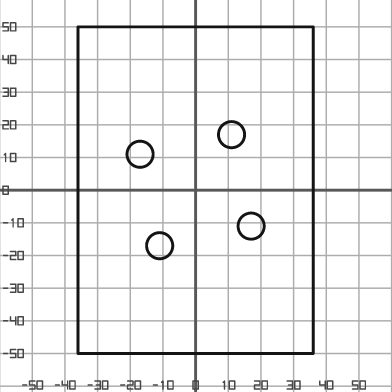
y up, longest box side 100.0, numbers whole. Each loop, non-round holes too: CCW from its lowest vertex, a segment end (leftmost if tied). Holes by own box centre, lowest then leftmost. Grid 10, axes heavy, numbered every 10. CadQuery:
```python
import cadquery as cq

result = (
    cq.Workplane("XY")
    .moveTo(-36.0, -50.0)
    .lineTo(36.0, -50.0)
    .lineTo(36.0, 50.0)
    .lineTo(-36.0, 50.0)
    .close()
    .moveTo(-11.0, -17.0)
    .circle(4.0)
    .moveTo(17.0, -11.0)
    .circle(4.0)
    .moveTo(-17.0, 11.0)
    .circle(4.0)
    .moveTo(11.0, 17.0)
    .circle(4.0)
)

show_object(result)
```